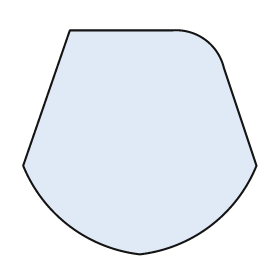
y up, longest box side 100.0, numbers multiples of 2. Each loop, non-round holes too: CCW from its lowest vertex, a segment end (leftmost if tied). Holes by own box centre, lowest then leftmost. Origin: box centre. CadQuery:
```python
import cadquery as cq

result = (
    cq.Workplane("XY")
    .moveTo(0.0, -48.0)
    .threePointArc((30.0, -36.0), (50.0, -10.0))
    .lineTo(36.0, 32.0)
    .threePointArc((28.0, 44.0), (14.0, 48.0))
    .lineTo(-30.0, 48.0)
    .lineTo(-50.0, -10.0)
    .threePointArc((-30.0, -36.0), (0.0, -48.0))
    .close()
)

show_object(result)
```